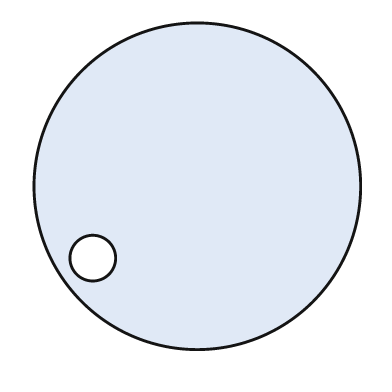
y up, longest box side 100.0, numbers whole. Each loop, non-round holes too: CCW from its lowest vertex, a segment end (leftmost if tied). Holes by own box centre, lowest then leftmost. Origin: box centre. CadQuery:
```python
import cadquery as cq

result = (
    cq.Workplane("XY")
    .moveTo(0.0, 0.0)
    .circle(50.0)
    .moveTo(-32.0, -22.0)
    .circle(7.0)
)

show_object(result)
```